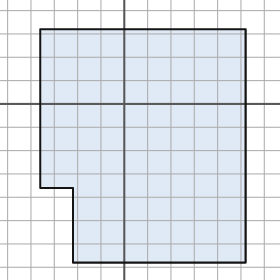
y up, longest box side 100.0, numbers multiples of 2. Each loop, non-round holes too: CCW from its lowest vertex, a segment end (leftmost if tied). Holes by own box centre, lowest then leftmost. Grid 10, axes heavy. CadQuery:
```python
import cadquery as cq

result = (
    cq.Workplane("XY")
    .moveTo(-22.0, -68.0)
    .lineTo(52.0, -68.0)
    .lineTo(52.0, 32.0)
    .lineTo(-36.0, 32.0)
    .lineTo(-36.0, -36.0)
    .lineTo(-22.0, -36.0)
    .close()
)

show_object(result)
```